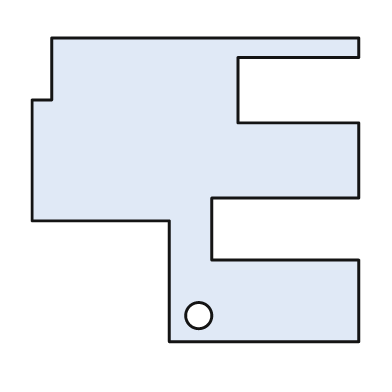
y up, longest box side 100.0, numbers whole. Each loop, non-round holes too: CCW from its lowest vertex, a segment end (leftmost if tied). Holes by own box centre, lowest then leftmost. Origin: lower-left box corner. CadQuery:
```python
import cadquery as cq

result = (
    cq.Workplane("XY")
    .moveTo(42.0, 0.0)
    .lineTo(100.0, 0.0)
    .lineTo(100.0, 25.0)
    .lineTo(55.0, 25.0)
    .lineTo(55.0, 44.0)
    .lineTo(100.0, 44.0)
    .lineTo(100.0, 67.0)
    .lineTo(63.0, 67.0)
    .lineTo(63.0, 87.0)
    .lineTo(100.0, 87.0)
    .lineTo(100.0, 93.0)
    .lineTo(6.0, 93.0)
    .lineTo(6.0, 74.0)
    .lineTo(0.0, 74.0)
    .lineTo(0.0, 37.0)
    .lineTo(42.0, 37.0)
    .close()
    .moveTo(51.0, 8.0)
    .circle(4.0)
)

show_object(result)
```